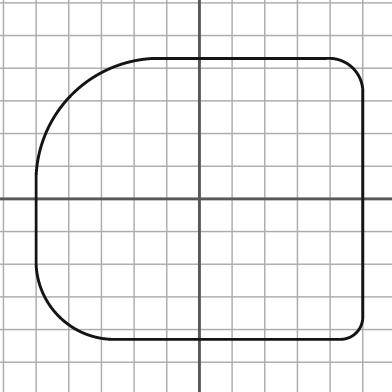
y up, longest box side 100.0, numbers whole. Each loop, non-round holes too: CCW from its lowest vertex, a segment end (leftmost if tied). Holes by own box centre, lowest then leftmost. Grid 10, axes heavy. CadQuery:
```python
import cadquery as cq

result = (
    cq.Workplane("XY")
    .moveTo(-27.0, -43.0)
    .lineTo(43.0, -43.0)
    .threePointArc((48.0, -41.0), (50.0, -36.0))
    .lineTo(50.0, 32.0)
    .threePointArc((47.0, 40.0), (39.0, 43.0))
    .lineTo(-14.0, 43.0)
    .threePointArc((-39.0, 32.0), (-50.0, 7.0))
    .lineTo(-50.0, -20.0)
    .threePointArc((-43.0, -36.0), (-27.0, -43.0))
    .close()
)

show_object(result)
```